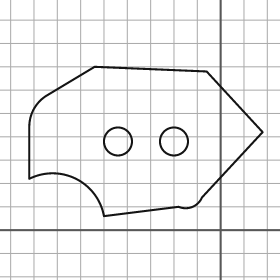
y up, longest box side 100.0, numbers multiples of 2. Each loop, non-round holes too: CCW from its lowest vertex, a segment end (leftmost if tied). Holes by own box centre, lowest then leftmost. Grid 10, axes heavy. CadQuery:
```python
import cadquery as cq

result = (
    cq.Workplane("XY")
    .moveTo(-50.0, 6.0)
    .lineTo(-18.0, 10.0)
    .threePointArc((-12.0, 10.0), (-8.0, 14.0))
    .lineTo(18.0, 42.0)
    .lineTo(-6.0, 68.0)
    .lineTo(-54.0, 70.0)
    .lineTo(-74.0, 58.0)
    .threePointArc((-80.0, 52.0), (-82.0, 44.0))
    .lineTo(-82.0, 22.0)
    .threePointArc((-62.0, 22.0), (-50.0, 6.0))
    .close()
    .moveTo(-44.0, 38.0)
    .circle(6.0)
    .moveTo(-20.0, 38.0)
    .circle(6.0)
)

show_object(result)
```